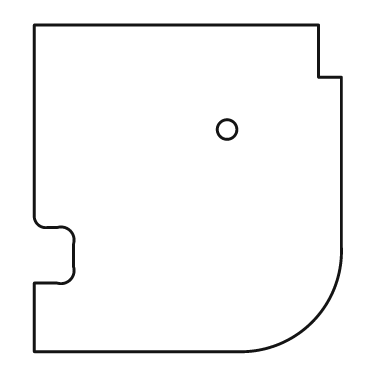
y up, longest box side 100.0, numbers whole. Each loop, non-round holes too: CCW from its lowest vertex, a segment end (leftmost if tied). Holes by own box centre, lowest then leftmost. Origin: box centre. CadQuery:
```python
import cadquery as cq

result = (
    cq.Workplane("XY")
    .moveTo(-47.0, -50.0)
    .lineTo(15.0, -50.0)
    .threePointArc((38.0, -41.0), (47.0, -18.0))
    .lineTo(47.0, 34.0)
    .lineTo(40.0, 34.0)
    .lineTo(40.0, 50.0)
    .lineTo(-47.0, 50.0)
    .lineTo(-47.0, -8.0)
    .threePointArc((-46.0, -11.0), (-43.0, -12.0))
    .lineTo(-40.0, -12.0)
    .threePointArc((-36.0, -13.0), (-35.0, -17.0))
    .lineTo(-35.0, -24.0)
    .threePointArc((-36.0, -28.0), (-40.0, -29.0))
    .lineTo(-47.0, -29.0)
    .close()
    .moveTo(12.0, 18.0)
    .circle(3.0)
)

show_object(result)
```